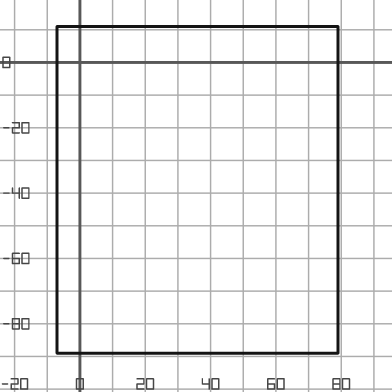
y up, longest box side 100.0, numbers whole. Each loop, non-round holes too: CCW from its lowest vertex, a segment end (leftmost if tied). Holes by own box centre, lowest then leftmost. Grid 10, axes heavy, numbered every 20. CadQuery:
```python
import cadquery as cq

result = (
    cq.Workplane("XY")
    .moveTo(-7.0, -89.0)
    .lineTo(79.0, -89.0)
    .lineTo(79.0, 11.0)
    .lineTo(-7.0, 11.0)
    .close()
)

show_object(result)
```